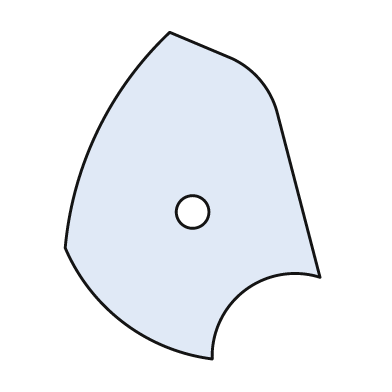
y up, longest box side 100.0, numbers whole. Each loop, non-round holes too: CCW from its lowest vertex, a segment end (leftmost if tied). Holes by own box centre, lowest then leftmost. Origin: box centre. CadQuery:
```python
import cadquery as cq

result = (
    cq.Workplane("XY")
    .moveTo(6.0, -50.0)
    .threePointArc((16.0, -29.0), (39.0, -25.0))
    .lineTo(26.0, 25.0)
    .threePointArc((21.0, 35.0), (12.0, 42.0))
    .lineTo(-7.0, 50.0)
    .threePointArc((-29.0, 20.0), (-39.0, -16.0))
    .threePointArc((-21.0, -39.0), (6.0, -50.0))
    .close()
    .moveTo(0.0, -5.0)
    .circle(5.0)
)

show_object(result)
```